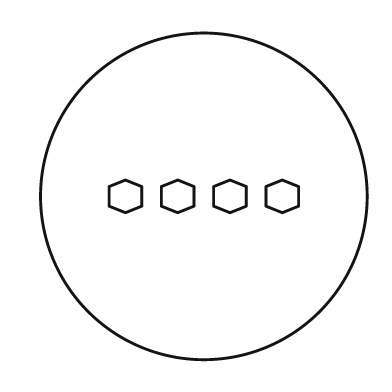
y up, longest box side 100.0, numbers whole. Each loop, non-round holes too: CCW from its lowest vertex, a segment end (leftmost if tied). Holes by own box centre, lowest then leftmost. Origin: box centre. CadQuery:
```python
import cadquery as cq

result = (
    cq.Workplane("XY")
    .moveTo(0.0, 0.0)
    .circle(50.0)
    .moveTo(-24.0, -5.0)
    .lineTo(-19.0, -3.0)
    .lineTo(-19.0, 3.0)
    .lineTo(-24.0, 5.0)
    .lineTo(-29.0, 3.0)
    .lineTo(-29.0, -3.0)
    .close()
    .moveTo(-8.0, -5.0)
    .lineTo(-3.0, -3.0)
    .lineTo(-3.0, 3.0)
    .lineTo(-8.0, 5.0)
    .lineTo(-13.0, 3.0)
    .lineTo(-13.0, -3.0)
    .close()
    .moveTo(8.0, -5.0)
    .lineTo(13.0, -3.0)
    .lineTo(13.0, 3.0)
    .lineTo(8.0, 5.0)
    .lineTo(3.0, 3.0)
    .lineTo(3.0, -3.0)
    .close()
    .moveTo(24.0, -5.0)
    .lineTo(29.0, -3.0)
    .lineTo(29.0, 3.0)
    .lineTo(24.0, 5.0)
    .lineTo(19.0, 3.0)
    .lineTo(19.0, -3.0)
    .close()
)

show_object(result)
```